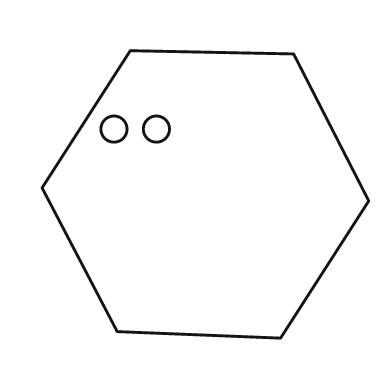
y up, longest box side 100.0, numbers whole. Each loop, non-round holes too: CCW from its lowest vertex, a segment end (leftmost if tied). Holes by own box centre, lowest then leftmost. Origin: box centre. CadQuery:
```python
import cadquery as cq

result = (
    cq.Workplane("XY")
    .moveTo(23.0, -44.0)
    .lineTo(50.0, -2.0)
    .lineTo(27.0, 43.0)
    .lineTo(-23.0, 44.0)
    .lineTo(-50.0, 2.0)
    .lineTo(-27.0, -42.0)
    .close()
    .moveTo(-28.0, 20.0)
    .circle(4.0)
    .moveTo(-15.0, 20.0)
    .circle(4.0)
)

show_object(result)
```